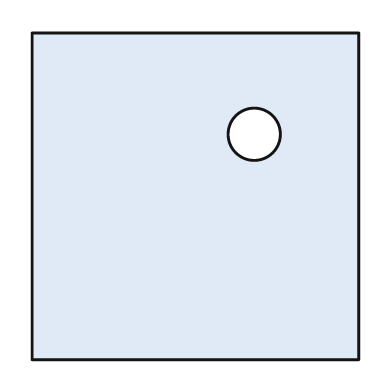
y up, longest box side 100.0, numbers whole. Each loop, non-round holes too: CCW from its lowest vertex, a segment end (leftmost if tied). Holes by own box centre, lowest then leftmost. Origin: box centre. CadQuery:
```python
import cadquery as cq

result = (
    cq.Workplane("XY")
    .moveTo(-50.0, -50.0)
    .lineTo(50.0, -50.0)
    .lineTo(50.0, 50.0)
    .lineTo(-50.0, 50.0)
    .close()
    .moveTo(18.0, 19.0)
    .circle(8.0)
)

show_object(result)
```